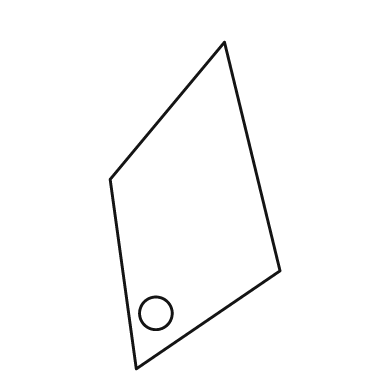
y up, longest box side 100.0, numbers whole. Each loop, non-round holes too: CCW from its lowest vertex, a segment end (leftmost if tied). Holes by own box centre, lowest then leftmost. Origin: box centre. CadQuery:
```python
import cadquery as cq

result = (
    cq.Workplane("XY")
    .moveTo(-18.0, -50.0)
    .lineTo(26.0, -20.0)
    .lineTo(9.0, 50.0)
    .lineTo(-26.0, 8.0)
    .close()
    .moveTo(-12.0, -33.0)
    .circle(5.0)
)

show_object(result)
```